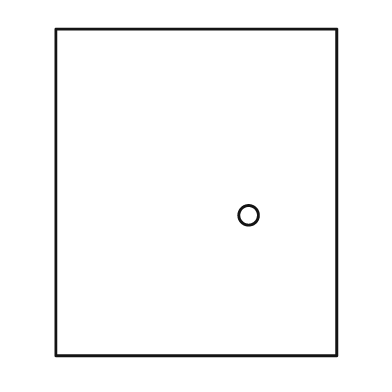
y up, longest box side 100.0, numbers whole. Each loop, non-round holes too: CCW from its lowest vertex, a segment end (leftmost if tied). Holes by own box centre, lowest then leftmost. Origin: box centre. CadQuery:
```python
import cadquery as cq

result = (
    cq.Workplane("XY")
    .moveTo(-43.0, -50.0)
    .lineTo(43.0, -50.0)
    .lineTo(43.0, 50.0)
    .lineTo(-43.0, 50.0)
    .close()
    .moveTo(16.0, -7.0)
    .circle(3.0)
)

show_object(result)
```